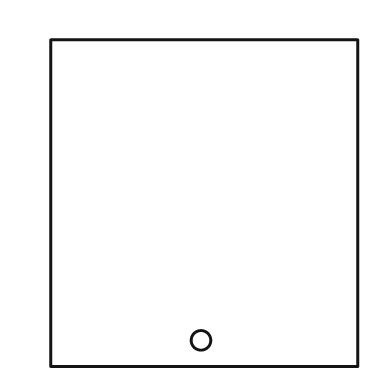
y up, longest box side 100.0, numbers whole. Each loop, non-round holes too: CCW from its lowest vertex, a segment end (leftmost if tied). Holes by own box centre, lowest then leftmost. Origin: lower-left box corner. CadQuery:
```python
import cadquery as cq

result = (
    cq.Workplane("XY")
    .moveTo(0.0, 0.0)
    .lineTo(94.0, 0.0)
    .lineTo(94.0, 100.0)
    .lineTo(0.0, 100.0)
    .close()
    .moveTo(46.0, 8.0)
    .circle(3.0)
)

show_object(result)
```